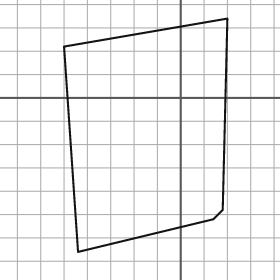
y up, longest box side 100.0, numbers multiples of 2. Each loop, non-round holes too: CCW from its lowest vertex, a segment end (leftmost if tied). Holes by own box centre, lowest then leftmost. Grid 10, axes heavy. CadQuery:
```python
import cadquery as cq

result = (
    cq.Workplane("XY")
    .moveTo(-44.0, -66.0)
    .lineTo(14.0, -52.0)
    .lineTo(18.0, -48.0)
    .lineTo(20.0, 34.0)
    .lineTo(-50.0, 22.0)
    .close()
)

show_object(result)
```